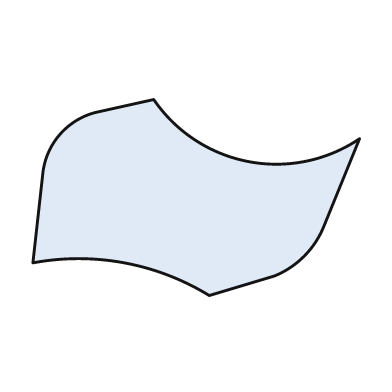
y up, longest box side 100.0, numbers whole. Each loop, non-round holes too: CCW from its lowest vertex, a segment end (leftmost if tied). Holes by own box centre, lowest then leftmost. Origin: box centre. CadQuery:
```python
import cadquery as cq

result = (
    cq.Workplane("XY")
    .moveTo(4.0, -30.0)
    .lineTo(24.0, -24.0)
    .threePointArc((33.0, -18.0), (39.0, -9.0))
    .lineTo(50.0, 18.0)
    .threePointArc((16.0, 11.0), (-13.0, 30.0))
    .lineTo(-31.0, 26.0)
    .threePointArc((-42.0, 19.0), (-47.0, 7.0))
    .lineTo(-50.0, -20.0)
    .threePointArc((-22.0, -20.0), (4.0, -30.0))
    .close()
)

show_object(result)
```